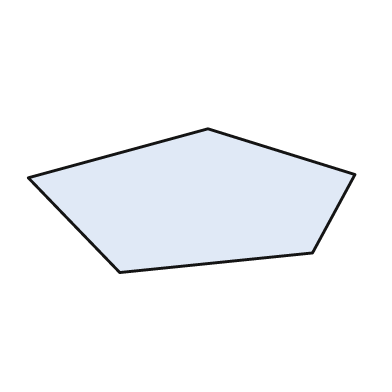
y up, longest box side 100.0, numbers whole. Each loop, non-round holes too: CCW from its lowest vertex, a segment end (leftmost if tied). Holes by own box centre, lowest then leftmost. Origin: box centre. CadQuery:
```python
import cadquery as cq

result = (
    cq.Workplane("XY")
    .moveTo(-22.0, -22.0)
    .lineTo(37.0, -16.0)
    .lineTo(50.0, 8.0)
    .lineTo(5.0, 22.0)
    .lineTo(-50.0, 7.0)
    .close()
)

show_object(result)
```